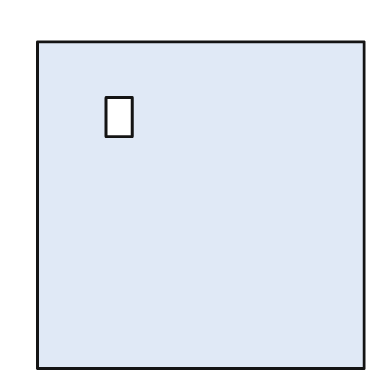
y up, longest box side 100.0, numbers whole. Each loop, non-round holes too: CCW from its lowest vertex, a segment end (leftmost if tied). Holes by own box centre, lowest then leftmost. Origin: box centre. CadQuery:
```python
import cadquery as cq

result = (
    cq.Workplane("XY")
    .moveTo(-50.0, -50.0)
    .lineTo(50.0, -50.0)
    .lineTo(50.0, 50.0)
    .lineTo(-50.0, 50.0)
    .close()
    .moveTo(-29.0, 21.0)
    .lineTo(-21.0, 21.0)
    .lineTo(-21.0, 33.0)
    .lineTo(-29.0, 33.0)
    .close()
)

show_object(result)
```